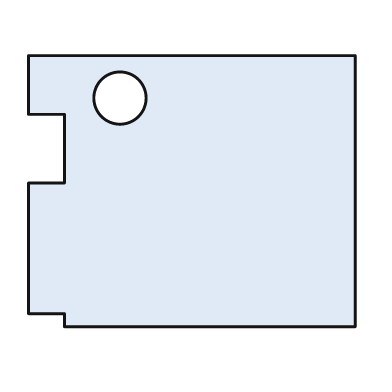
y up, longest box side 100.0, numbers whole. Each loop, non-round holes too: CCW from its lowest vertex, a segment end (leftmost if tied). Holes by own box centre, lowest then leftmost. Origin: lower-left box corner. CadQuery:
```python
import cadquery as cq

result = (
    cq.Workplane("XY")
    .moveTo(11.0, 0.0)
    .lineTo(100.0, 0.0)
    .lineTo(100.0, 83.0)
    .lineTo(0.0, 83.0)
    .lineTo(0.0, 65.0)
    .lineTo(11.0, 65.0)
    .lineTo(11.0, 44.0)
    .lineTo(0.0, 44.0)
    .lineTo(0.0, 4.0)
    .lineTo(11.0, 4.0)
    .close()
    .moveTo(28.0, 70.0)
    .circle(8.0)
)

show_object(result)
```